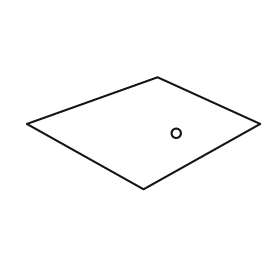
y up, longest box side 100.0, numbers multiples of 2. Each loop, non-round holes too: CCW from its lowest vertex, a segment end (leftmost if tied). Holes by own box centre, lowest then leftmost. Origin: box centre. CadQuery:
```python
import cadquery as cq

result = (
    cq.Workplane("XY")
    .moveTo(0.0, -24.0)
    .lineTo(50.0, 4.0)
    .lineTo(6.0, 24.0)
    .lineTo(-50.0, 4.0)
    .close()
    .moveTo(14.0, 0.0)
    .circle(2.0)
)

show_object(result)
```